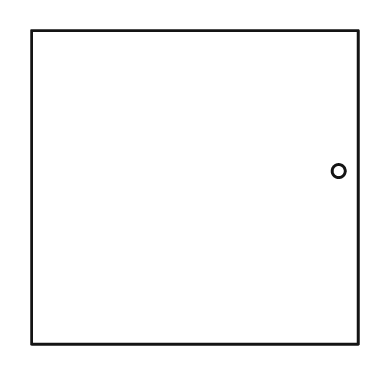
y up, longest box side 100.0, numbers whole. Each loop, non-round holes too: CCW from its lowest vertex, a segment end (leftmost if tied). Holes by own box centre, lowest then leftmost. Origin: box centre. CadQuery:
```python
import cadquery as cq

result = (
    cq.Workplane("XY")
    .moveTo(-50.0, -48.0)
    .lineTo(50.0, -48.0)
    .lineTo(50.0, 48.0)
    .lineTo(-50.0, 48.0)
    .close()
    .moveTo(44.0, 5.0)
    .circle(2.0)
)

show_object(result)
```